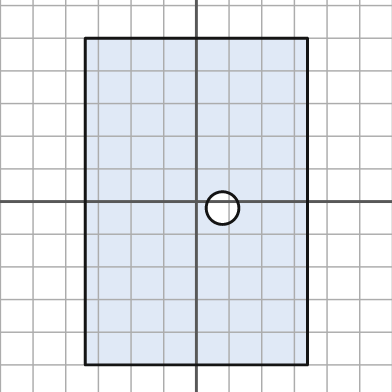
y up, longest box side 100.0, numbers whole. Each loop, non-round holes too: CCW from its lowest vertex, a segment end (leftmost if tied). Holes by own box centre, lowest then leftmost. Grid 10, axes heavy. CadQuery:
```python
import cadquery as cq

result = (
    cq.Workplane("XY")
    .moveTo(-34.0, -50.0)
    .lineTo(34.0, -50.0)
    .lineTo(34.0, 50.0)
    .lineTo(-34.0, 50.0)
    .close()
    .moveTo(8.0, -2.0)
    .circle(5.0)
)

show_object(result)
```